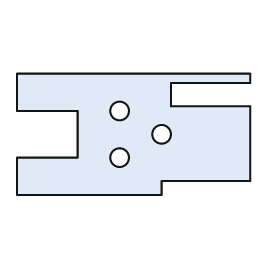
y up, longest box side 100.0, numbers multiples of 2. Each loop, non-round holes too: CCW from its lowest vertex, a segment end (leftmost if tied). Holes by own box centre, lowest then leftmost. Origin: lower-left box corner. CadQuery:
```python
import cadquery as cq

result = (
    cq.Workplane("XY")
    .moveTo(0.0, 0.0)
    .lineTo(62.0, 0.0)
    .lineTo(62.0, 6.0)
    .lineTo(100.0, 6.0)
    .lineTo(100.0, 38.0)
    .lineTo(66.0, 38.0)
    .lineTo(66.0, 48.0)
    .lineTo(100.0, 48.0)
    .lineTo(100.0, 52.0)
    .lineTo(0.0, 52.0)
    .lineTo(0.0, 36.0)
    .lineTo(26.0, 36.0)
    .lineTo(26.0, 16.0)
    .lineTo(0.0, 16.0)
    .close()
    .moveTo(44.0, 16.0)
    .circle(4.0)
    .moveTo(62.0, 26.0)
    .circle(4.0)
    .moveTo(44.0, 36.0)
    .circle(4.0)
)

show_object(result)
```